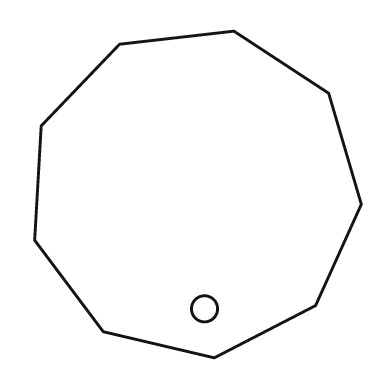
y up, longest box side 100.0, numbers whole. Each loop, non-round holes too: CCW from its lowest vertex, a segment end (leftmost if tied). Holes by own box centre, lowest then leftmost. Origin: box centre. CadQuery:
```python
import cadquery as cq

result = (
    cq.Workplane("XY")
    .moveTo(5.0, -50.0)
    .lineTo(36.0, -34.0)
    .lineTo(50.0, -3.0)
    .lineTo(40.0, 31.0)
    .lineTo(11.0, 50.0)
    .lineTo(-24.0, 46.0)
    .lineTo(-48.0, 21.0)
    .lineTo(-50.0, -14.0)
    .lineTo(-29.0, -42.0)
    .close()
    .moveTo(2.0, -35.0)
    .circle(4.0)
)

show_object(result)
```